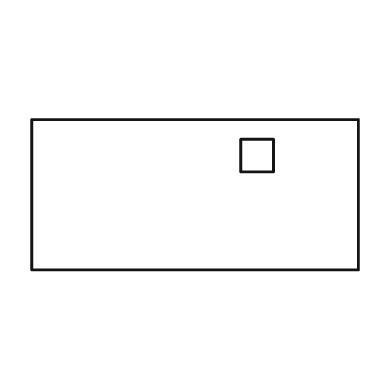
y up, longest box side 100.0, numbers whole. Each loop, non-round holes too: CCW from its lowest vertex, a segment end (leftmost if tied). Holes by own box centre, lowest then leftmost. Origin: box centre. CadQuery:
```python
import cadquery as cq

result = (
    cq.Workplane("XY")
    .moveTo(-50.0, -23.0)
    .lineTo(50.0, -23.0)
    .lineTo(50.0, 23.0)
    .lineTo(-50.0, 23.0)
    .close()
    .moveTo(14.0, 7.0)
    .lineTo(24.0, 7.0)
    .lineTo(24.0, 17.0)
    .lineTo(14.0, 17.0)
    .close()
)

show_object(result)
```